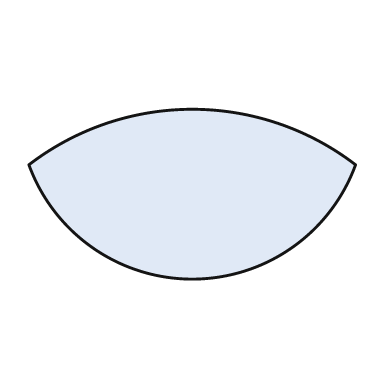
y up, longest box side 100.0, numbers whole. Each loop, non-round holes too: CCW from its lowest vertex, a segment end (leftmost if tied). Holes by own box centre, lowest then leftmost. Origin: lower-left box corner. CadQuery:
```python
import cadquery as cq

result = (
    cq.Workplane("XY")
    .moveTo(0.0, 35.0)
    .threePointArc((50.0, 0.0), (100.0, 35.0))
    .threePointArc((50.0, 52.0), (0.0, 35.0))
    .close()
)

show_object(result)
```